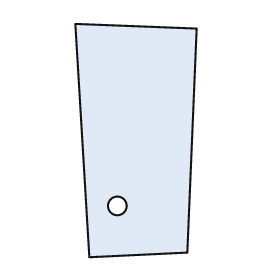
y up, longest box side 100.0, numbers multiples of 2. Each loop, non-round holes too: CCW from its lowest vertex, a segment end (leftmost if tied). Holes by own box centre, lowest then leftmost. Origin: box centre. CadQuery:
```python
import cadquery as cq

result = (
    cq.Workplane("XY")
    .moveTo(-20.0, -50.0)
    .lineTo(22.0, -48.0)
    .lineTo(26.0, 48.0)
    .lineTo(-26.0, 50.0)
    .close()
    .moveTo(-8.0, -28.0)
    .circle(4.0)
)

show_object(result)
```